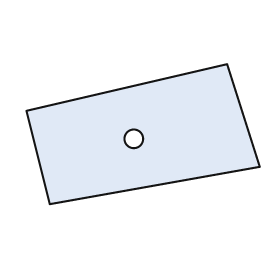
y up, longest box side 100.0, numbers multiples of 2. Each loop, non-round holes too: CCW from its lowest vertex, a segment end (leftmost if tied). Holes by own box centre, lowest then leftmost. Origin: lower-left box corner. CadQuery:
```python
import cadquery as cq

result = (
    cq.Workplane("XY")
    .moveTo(10.0, 0.0)
    .lineTo(100.0, 16.0)
    .lineTo(86.0, 60.0)
    .lineTo(0.0, 40.0)
    .close()
    .moveTo(46.0, 28.0)
    .circle(4.0)
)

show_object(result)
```